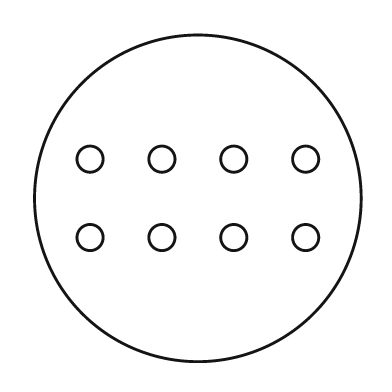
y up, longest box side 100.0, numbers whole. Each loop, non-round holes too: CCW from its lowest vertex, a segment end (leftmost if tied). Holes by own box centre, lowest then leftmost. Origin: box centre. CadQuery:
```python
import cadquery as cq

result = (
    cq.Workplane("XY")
    .moveTo(0.0, 0.0)
    .circle(50.0)
    .moveTo(-33.0, -12.0)
    .circle(4.0)
    .moveTo(-11.0, -12.0)
    .circle(4.0)
    .moveTo(11.0, -12.0)
    .circle(4.0)
    .moveTo(33.0, -12.0)
    .circle(4.0)
    .moveTo(-33.0, 12.0)
    .circle(4.0)
    .moveTo(-11.0, 12.0)
    .circle(4.0)
    .moveTo(11.0, 12.0)
    .circle(4.0)
    .moveTo(33.0, 12.0)
    .circle(4.0)
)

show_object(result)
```